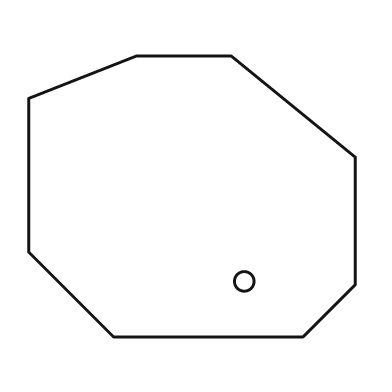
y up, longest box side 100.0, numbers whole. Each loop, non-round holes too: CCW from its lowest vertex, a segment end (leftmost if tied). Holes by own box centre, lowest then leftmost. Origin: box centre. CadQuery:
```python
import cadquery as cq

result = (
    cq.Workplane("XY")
    .moveTo(-24.0, -43.0)
    .lineTo(34.0, -43.0)
    .lineTo(50.0, -27.0)
    .lineTo(50.0, 12.0)
    .lineTo(12.0, 43.0)
    .lineTo(-17.0, 43.0)
    .lineTo(-50.0, 30.0)
    .lineTo(-50.0, -17.0)
    .close()
    .moveTo(16.0, -26.0)
    .circle(3.0)
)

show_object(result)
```